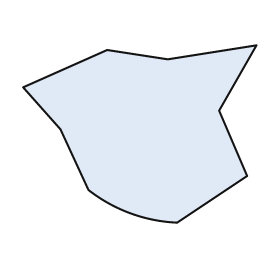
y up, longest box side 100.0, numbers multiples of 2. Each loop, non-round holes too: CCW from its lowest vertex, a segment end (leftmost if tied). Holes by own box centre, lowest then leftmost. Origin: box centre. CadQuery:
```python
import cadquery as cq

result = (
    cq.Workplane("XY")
    .moveTo(16.0, -38.0)
    .lineTo(46.0, -18.0)
    .lineTo(34.0, 10.0)
    .lineTo(50.0, 38.0)
    .lineTo(12.0, 32.0)
    .lineTo(-14.0, 36.0)
    .lineTo(-50.0, 20.0)
    .lineTo(-34.0, 2.0)
    .lineTo(-22.0, -24.0)
    .threePointArc((-4.0, -34.0), (16.0, -38.0))
    .close()
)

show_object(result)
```